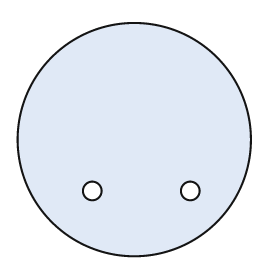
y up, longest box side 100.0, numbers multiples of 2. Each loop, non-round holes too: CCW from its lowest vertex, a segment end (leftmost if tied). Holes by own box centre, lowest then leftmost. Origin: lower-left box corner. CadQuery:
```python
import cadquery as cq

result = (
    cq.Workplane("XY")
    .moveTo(50.0, 50.0)
    .circle(50.0)
    .moveTo(32.0, 28.0)
    .circle(4.0)
    .moveTo(74.0, 28.0)
    .circle(4.0)
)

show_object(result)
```